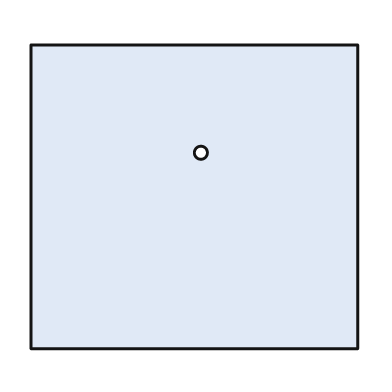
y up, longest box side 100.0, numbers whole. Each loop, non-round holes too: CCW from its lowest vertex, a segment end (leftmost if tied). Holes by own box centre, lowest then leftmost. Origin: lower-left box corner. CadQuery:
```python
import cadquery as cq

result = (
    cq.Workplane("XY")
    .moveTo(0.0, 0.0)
    .lineTo(100.0, 0.0)
    .lineTo(100.0, 93.0)
    .lineTo(0.0, 93.0)
    .close()
    .moveTo(52.0, 60.0)
    .circle(2.0)
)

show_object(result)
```